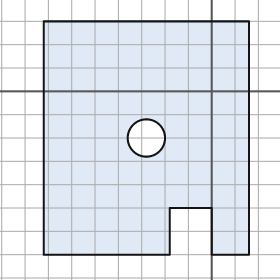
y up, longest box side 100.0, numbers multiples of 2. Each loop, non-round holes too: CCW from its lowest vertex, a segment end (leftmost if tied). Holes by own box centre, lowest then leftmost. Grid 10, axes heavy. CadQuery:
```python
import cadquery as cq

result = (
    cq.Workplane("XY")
    .moveTo(-72.0, -70.0)
    .lineTo(-18.0, -70.0)
    .lineTo(-18.0, -50.0)
    .lineTo(0.0, -50.0)
    .lineTo(0.0, -70.0)
    .lineTo(16.0, -70.0)
    .lineTo(16.0, 30.0)
    .lineTo(-72.0, 30.0)
    .close()
    .moveTo(-28.0, -20.0)
    .circle(8.0)
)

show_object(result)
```